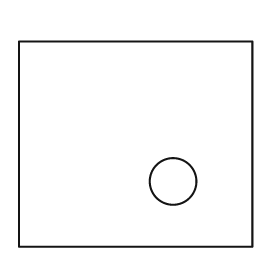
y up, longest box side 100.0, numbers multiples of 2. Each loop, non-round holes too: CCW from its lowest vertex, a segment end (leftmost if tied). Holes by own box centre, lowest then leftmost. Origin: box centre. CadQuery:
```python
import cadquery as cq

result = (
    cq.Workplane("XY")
    .moveTo(-50.0, -44.0)
    .lineTo(50.0, -44.0)
    .lineTo(50.0, 44.0)
    .lineTo(-50.0, 44.0)
    .close()
    .moveTo(16.0, -16.0)
    .circle(10.0)
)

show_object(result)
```